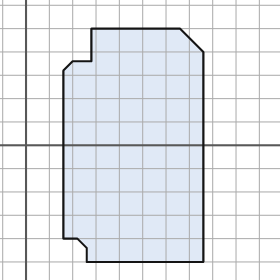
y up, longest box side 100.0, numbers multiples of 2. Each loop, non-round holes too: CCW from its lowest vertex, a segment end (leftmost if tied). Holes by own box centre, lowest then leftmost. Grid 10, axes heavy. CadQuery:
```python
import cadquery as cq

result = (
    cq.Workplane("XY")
    .moveTo(26.0, -50.0)
    .lineTo(76.0, -50.0)
    .lineTo(76.0, 40.0)
    .lineTo(66.0, 50.0)
    .lineTo(28.0, 50.0)
    .lineTo(28.0, 36.0)
    .lineTo(20.0, 36.0)
    .lineTo(16.0, 32.0)
    .lineTo(16.0, -40.0)
    .lineTo(22.0, -40.0)
    .lineTo(26.0, -44.0)
    .close()
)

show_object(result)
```